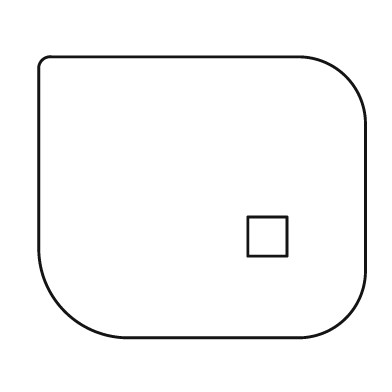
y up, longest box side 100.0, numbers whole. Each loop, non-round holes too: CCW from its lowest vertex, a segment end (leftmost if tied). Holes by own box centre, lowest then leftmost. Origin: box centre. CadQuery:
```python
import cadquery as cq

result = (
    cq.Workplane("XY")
    .moveTo(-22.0, -43.0)
    .lineTo(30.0, -43.0)
    .threePointArc((44.0, -37.0), (50.0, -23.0))
    .lineTo(50.0, 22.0)
    .threePointArc((44.0, 37.0), (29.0, 43.0))
    .lineTo(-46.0, 43.0)
    .threePointArc((-49.0, 42.0), (-50.0, 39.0))
    .lineTo(-50.0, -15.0)
    .threePointArc((-42.0, -35.0), (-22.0, -43.0))
    .close()
    .moveTo(14.0, -18.0)
    .lineTo(26.0, -18.0)
    .lineTo(26.0, -6.0)
    .lineTo(14.0, -6.0)
    .close()
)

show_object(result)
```